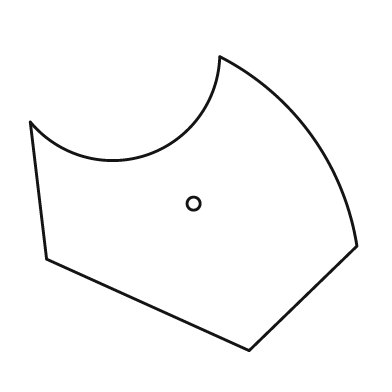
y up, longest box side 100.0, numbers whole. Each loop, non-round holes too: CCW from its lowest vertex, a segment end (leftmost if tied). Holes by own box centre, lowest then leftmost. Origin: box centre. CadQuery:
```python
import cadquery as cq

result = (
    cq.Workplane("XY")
    .moveTo(17.0, -45.0)
    .lineTo(50.0, -13.0)
    .threePointArc((36.0, 21.0), (8.0, 45.0))
    .threePointArc((-14.0, 15.0), (-50.0, 25.0))
    .lineTo(-45.0, -17.0)
    .close()
    .moveTo(0.0, 0.0)
    .circle(2.0)
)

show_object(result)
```